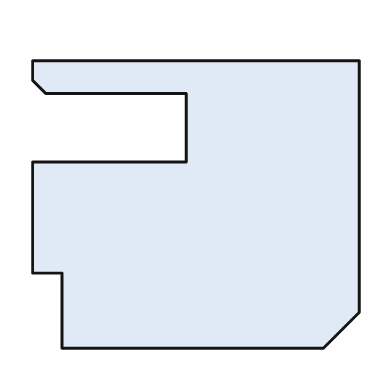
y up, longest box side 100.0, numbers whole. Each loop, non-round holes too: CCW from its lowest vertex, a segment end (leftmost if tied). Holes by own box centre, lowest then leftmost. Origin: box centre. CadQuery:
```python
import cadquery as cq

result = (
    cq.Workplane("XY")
    .moveTo(-41.0, -44.0)
    .lineTo(39.0, -44.0)
    .lineTo(50.0, -33.0)
    .lineTo(50.0, 44.0)
    .lineTo(-50.0, 44.0)
    .lineTo(-50.0, 38.0)
    .lineTo(-46.0, 34.0)
    .lineTo(-3.0, 34.0)
    .lineTo(-3.0, 13.0)
    .lineTo(-50.0, 13.0)
    .lineTo(-50.0, -21.0)
    .lineTo(-41.0, -21.0)
    .close()
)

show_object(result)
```